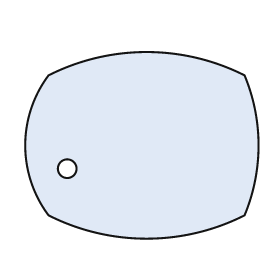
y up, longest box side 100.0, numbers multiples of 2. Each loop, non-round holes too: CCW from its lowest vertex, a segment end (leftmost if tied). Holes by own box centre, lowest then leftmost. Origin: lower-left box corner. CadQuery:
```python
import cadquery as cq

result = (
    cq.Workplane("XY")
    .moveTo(10.0, 10.0)
    .threePointArc((52.0, 0.0), (94.0, 10.0))
    .threePointArc((100.0, 40.0), (94.0, 70.0))
    .threePointArc((52.0, 80.0), (10.0, 70.0))
    .threePointArc((0.0, 40.0), (10.0, 10.0))
    .close()
    .moveTo(18.0, 30.0)
    .circle(4.0)
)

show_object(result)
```